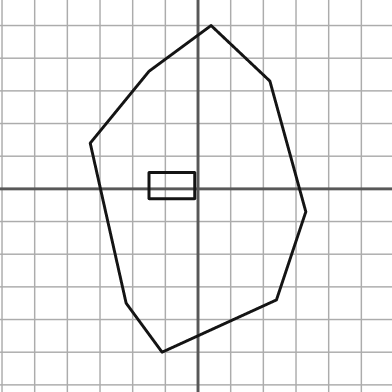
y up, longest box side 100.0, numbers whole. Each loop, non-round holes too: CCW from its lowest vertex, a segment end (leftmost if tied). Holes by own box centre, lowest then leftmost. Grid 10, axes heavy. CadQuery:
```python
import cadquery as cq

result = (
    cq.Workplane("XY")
    .moveTo(-11.0, -50.0)
    .lineTo(24.0, -34.0)
    .lineTo(33.0, -7.0)
    .lineTo(22.0, 33.0)
    .lineTo(4.0, 50.0)
    .lineTo(-15.0, 36.0)
    .lineTo(-33.0, 14.0)
    .lineTo(-22.0, -35.0)
    .close()
    .moveTo(-15.0, -3.0)
    .lineTo(-1.0, -3.0)
    .lineTo(-1.0, 5.0)
    .lineTo(-15.0, 5.0)
    .close()
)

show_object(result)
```